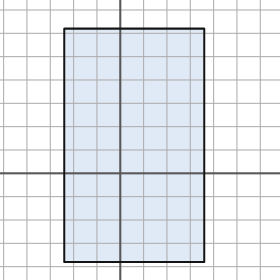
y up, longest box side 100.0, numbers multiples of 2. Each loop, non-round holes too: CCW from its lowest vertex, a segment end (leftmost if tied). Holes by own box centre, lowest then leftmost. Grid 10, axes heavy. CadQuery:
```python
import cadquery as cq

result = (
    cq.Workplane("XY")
    .moveTo(-24.0, -38.0)
    .lineTo(36.0, -38.0)
    .lineTo(36.0, 62.0)
    .lineTo(-24.0, 62.0)
    .close()
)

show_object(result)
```